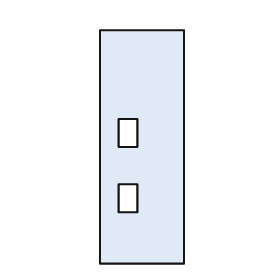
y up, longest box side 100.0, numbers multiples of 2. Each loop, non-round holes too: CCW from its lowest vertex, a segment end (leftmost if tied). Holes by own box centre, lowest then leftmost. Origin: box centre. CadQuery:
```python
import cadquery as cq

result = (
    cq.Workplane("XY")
    .moveTo(-18.0, -50.0)
    .lineTo(18.0, -50.0)
    .lineTo(18.0, 50.0)
    .lineTo(-18.0, 50.0)
    .close()
    .moveTo(-10.0, -28.0)
    .lineTo(-2.0, -28.0)
    .lineTo(-2.0, -16.0)
    .lineTo(-10.0, -16.0)
    .close()
    .moveTo(-10.0, 0.0)
    .lineTo(-2.0, 0.0)
    .lineTo(-2.0, 12.0)
    .lineTo(-10.0, 12.0)
    .close()
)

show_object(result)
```